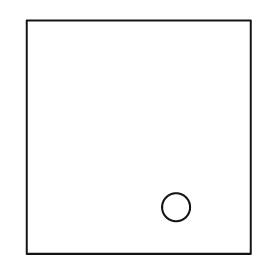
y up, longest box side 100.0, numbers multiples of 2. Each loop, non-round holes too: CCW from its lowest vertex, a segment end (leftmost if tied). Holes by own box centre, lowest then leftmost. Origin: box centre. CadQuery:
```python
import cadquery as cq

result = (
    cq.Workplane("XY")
    .moveTo(-48.0, -50.0)
    .lineTo(48.0, -50.0)
    .lineTo(48.0, 50.0)
    .lineTo(-48.0, 50.0)
    .close()
    .moveTo(16.0, -30.0)
    .circle(6.0)
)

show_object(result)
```